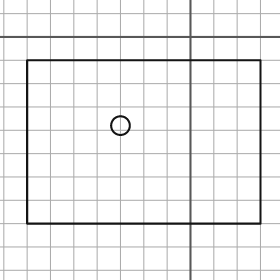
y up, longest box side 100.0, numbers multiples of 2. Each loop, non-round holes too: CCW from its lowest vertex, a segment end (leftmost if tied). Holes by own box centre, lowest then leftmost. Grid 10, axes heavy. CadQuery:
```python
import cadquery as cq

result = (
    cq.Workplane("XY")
    .moveTo(-70.0, -80.0)
    .lineTo(30.0, -80.0)
    .lineTo(30.0, -10.0)
    .lineTo(-70.0, -10.0)
    .close()
    .moveTo(-30.0, -38.0)
    .circle(4.0)
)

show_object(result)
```